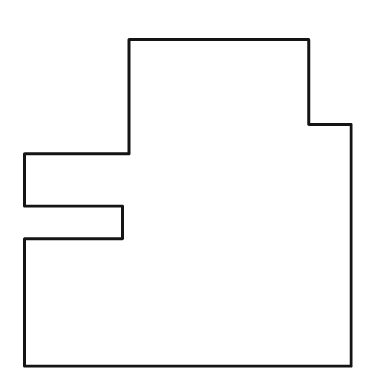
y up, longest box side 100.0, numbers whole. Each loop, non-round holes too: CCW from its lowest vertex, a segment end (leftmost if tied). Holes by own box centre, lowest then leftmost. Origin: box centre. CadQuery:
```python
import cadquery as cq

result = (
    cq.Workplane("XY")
    .moveTo(-50.0, -50.0)
    .lineTo(50.0, -50.0)
    .lineTo(50.0, 24.0)
    .lineTo(37.0, 24.0)
    .lineTo(37.0, 50.0)
    .lineTo(-18.0, 50.0)
    .lineTo(-18.0, 15.0)
    .lineTo(-50.0, 15.0)
    .lineTo(-50.0, -1.0)
    .lineTo(-20.0, -1.0)
    .lineTo(-20.0, -11.0)
    .lineTo(-50.0, -11.0)
    .close()
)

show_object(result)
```